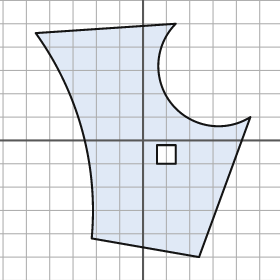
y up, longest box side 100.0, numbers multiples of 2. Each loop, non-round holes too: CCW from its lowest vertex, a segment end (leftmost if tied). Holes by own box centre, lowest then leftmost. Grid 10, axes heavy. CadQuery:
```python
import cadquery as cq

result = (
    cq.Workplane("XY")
    .moveTo(24.0, -50.0)
    .lineTo(46.0, 10.0)
    .threePointArc((12.0, 16.0), (14.0, 50.0))
    .lineTo(-46.0, 46.0)
    .threePointArc((-26.0, 4.0), (-22.0, -42.0))
    .close()
    .moveTo(6.0, -10.0)
    .lineTo(14.0, -10.0)
    .lineTo(14.0, -2.0)
    .lineTo(6.0, -2.0)
    .close()
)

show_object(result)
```